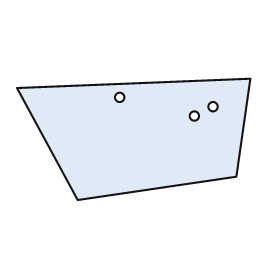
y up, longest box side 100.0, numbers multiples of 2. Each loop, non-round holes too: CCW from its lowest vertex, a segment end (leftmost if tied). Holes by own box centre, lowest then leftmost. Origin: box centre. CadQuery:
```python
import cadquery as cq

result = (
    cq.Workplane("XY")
    .moveTo(-24.0, -26.0)
    .lineTo(44.0, -16.0)
    .lineTo(50.0, 26.0)
    .lineTo(-50.0, 22.0)
    .close()
    .moveTo(26.0, 10.0)
    .circle(2.0)
    .moveTo(34.0, 14.0)
    .circle(2.0)
    .moveTo(-6.0, 18.0)
    .circle(2.0)
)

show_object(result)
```